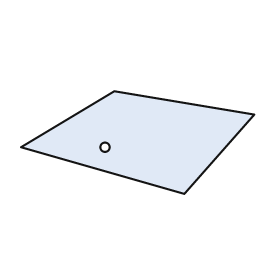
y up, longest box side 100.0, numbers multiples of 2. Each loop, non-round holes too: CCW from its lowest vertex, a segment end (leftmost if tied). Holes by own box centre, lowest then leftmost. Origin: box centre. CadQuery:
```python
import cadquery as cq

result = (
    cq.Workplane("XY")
    .moveTo(20.0, -22.0)
    .lineTo(50.0, 12.0)
    .lineTo(-10.0, 22.0)
    .lineTo(-50.0, -2.0)
    .close()
    .moveTo(-14.0, -2.0)
    .circle(2.0)
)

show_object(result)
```